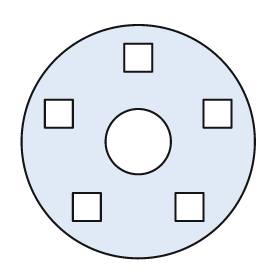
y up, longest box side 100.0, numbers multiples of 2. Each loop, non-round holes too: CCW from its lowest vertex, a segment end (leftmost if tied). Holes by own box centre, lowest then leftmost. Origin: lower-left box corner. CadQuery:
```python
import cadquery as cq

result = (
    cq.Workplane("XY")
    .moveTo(50.0, 50.0)
    .circle(50.0)
    .moveTo(22.0, 16.0)
    .lineTo(34.0, 16.0)
    .lineTo(34.0, 28.0)
    .lineTo(22.0, 28.0)
    .close()
    .moveTo(66.0, 16.0)
    .lineTo(78.0, 16.0)
    .lineTo(78.0, 28.0)
    .lineTo(66.0, 28.0)
    .close()
    .moveTo(50.0, 50.0)
    .circle(14.0)
    .moveTo(10.0, 56.0)
    .lineTo(22.0, 56.0)
    .lineTo(22.0, 68.0)
    .lineTo(10.0, 68.0)
    .close()
    .moveTo(78.0, 56.0)
    .lineTo(90.0, 56.0)
    .lineTo(90.0, 68.0)
    .lineTo(78.0, 68.0)
    .close()
    .moveTo(44.0, 80.0)
    .lineTo(56.0, 80.0)
    .lineTo(56.0, 92.0)
    .lineTo(44.0, 92.0)
    .close()
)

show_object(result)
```